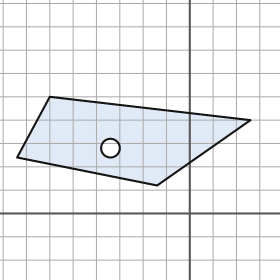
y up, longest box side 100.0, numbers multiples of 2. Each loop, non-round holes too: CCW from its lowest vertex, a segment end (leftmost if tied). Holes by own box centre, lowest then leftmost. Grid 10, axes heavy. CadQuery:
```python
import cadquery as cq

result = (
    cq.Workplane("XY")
    .moveTo(-14.0, 12.0)
    .lineTo(26.0, 40.0)
    .lineTo(-60.0, 50.0)
    .lineTo(-74.0, 24.0)
    .close()
    .moveTo(-34.0, 28.0)
    .circle(4.0)
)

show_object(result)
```